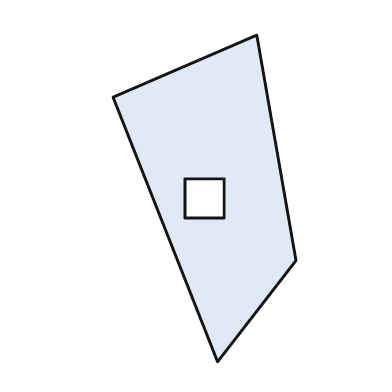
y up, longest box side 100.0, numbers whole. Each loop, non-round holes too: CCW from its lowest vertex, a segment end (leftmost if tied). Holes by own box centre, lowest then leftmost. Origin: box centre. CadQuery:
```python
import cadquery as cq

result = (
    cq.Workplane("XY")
    .moveTo(4.0, -50.0)
    .lineTo(28.0, -19.0)
    .lineTo(16.0, 50.0)
    .lineTo(-28.0, 31.0)
    .close()
    .moveTo(-6.0, -6.0)
    .lineTo(6.0, -6.0)
    .lineTo(6.0, 6.0)
    .lineTo(-6.0, 6.0)
    .close()
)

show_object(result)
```